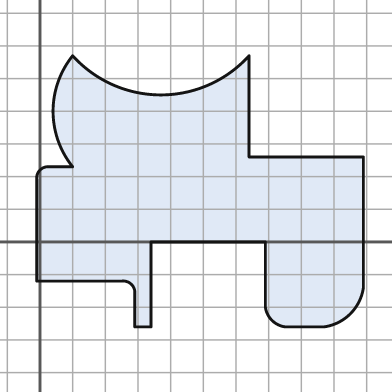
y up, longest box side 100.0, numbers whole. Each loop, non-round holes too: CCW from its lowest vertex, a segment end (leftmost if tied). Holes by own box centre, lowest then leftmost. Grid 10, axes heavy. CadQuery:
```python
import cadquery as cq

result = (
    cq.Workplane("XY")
    .moveTo(29.0, -26.0)
    .lineTo(34.0, -26.0)
    .lineTo(34.0, 0.0)
    .lineTo(69.0, 0.0)
    .lineTo(69.0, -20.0)
    .threePointArc((71.0, -24.0), (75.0, -26.0))
    .lineTo(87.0, -26.0)
    .threePointArc((95.0, -22.0), (99.0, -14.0))
    .lineTo(99.0, 26.0)
    .lineTo(64.0, 26.0)
    .lineTo(64.0, 57.0)
    .threePointArc((37.0, 45.0), (10.0, 57.0))
    .threePointArc((4.0, 40.0), (10.0, 23.0))
    .lineTo(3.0, 23.0)
    .threePointArc((0.0, 22.0), (-1.0, 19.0))
    .lineTo(-1.0, -12.0)
    .lineTo(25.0, -12.0)
    .threePointArc((28.0, -13.0), (29.0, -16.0))
    .close()
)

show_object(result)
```